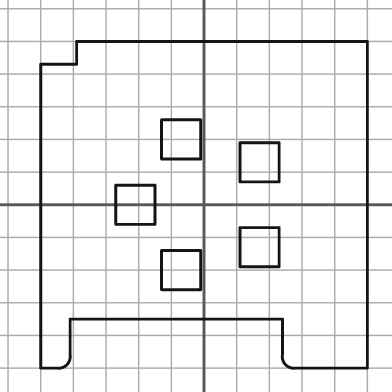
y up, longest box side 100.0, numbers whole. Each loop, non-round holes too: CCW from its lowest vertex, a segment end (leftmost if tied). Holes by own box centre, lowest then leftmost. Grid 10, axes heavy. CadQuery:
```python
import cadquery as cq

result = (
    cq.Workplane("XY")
    .moveTo(-50.0, -50.0)
    .lineTo(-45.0, -50.0)
    .threePointArc((-42.0, -49.0), (-41.0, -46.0))
    .lineTo(-41.0, -35.0)
    .lineTo(24.0, -35.0)
    .lineTo(24.0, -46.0)
    .threePointArc((25.0, -49.0), (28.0, -50.0))
    .lineTo(50.0, -50.0)
    .lineTo(50.0, 50.0)
    .lineTo(-39.0, 50.0)
    .lineTo(-39.0, 43.0)
    .lineTo(-50.0, 43.0)
    .close()
    .moveTo(-13.0, -26.0)
    .lineTo(-1.0, -26.0)
    .lineTo(-1.0, -14.0)
    .lineTo(-13.0, -14.0)
    .close()
    .moveTo(11.0, -19.0)
    .lineTo(23.0, -19.0)
    .lineTo(23.0, -7.0)
    .lineTo(11.0, -7.0)
    .close()
    .moveTo(-27.0, -6.0)
    .lineTo(-15.0, -6.0)
    .lineTo(-15.0, 6.0)
    .lineTo(-27.0, 6.0)
    .close()
    .moveTo(11.0, 7.0)
    .lineTo(23.0, 7.0)
    .lineTo(23.0, 19.0)
    .lineTo(11.0, 19.0)
    .close()
    .moveTo(-13.0, 14.0)
    .lineTo(-1.0, 14.0)
    .lineTo(-1.0, 26.0)
    .lineTo(-13.0, 26.0)
    .close()
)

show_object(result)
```